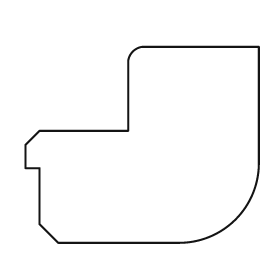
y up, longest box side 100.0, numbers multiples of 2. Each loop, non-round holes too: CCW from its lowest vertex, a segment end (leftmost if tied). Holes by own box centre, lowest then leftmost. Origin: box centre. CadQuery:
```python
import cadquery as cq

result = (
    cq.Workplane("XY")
    .moveTo(-36.0, -42.0)
    .lineTo(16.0, -42.0)
    .threePointArc((40.0, -32.0), (50.0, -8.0))
    .lineTo(50.0, 42.0)
    .lineTo(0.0, 42.0)
    .threePointArc((-4.0, 40.0), (-6.0, 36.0))
    .lineTo(-6.0, 6.0)
    .lineTo(-44.0, 6.0)
    .lineTo(-50.0, 0.0)
    .lineTo(-50.0, -10.0)
    .lineTo(-44.0, -10.0)
    .lineTo(-44.0, -34.0)
    .close()
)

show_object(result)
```